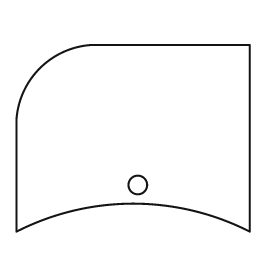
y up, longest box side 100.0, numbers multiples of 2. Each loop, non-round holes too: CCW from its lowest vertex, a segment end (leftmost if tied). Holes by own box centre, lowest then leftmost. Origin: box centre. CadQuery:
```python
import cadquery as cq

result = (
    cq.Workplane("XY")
    .moveTo(-50.0, -40.0)
    .threePointArc((0.0, -28.0), (50.0, -40.0))
    .lineTo(50.0, 40.0)
    .lineTo(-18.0, 40.0)
    .threePointArc((-40.0, 30.0), (-50.0, 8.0))
    .close()
    .moveTo(2.0, -20.0)
    .circle(4.0)
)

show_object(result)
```